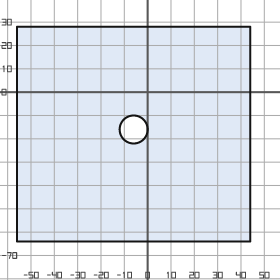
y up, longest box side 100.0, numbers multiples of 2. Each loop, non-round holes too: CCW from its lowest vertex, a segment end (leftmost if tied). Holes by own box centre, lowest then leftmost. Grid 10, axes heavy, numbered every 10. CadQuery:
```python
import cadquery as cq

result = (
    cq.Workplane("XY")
    .moveTo(-56.0, -64.0)
    .lineTo(44.0, -64.0)
    .lineTo(44.0, 28.0)
    .lineTo(-56.0, 28.0)
    .close()
    .moveTo(-6.0, -16.0)
    .circle(6.0)
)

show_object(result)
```